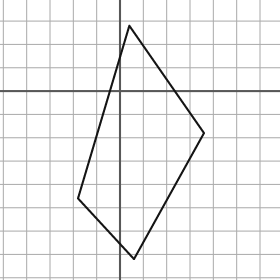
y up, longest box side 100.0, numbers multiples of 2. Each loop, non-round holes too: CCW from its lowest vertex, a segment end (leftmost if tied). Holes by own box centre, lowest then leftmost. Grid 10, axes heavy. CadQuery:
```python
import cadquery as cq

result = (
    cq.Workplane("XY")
    .moveTo(6.0, -72.0)
    .lineTo(36.0, -18.0)
    .lineTo(4.0, 28.0)
    .lineTo(-18.0, -46.0)
    .close()
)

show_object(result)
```